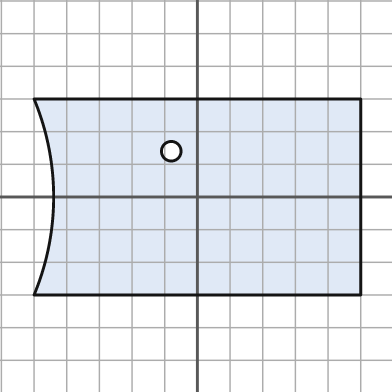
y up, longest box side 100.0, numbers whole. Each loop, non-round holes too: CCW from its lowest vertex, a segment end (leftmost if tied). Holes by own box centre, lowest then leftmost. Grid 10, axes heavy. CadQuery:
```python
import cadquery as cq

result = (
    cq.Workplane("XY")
    .moveTo(-50.0, -30.0)
    .lineTo(50.0, -30.0)
    .lineTo(50.0, 30.0)
    .lineTo(-50.0, 30.0)
    .threePointArc((-44.0, 0.0), (-50.0, -30.0))
    .close()
    .moveTo(-8.0, 14.0)
    .circle(3.0)
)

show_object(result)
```